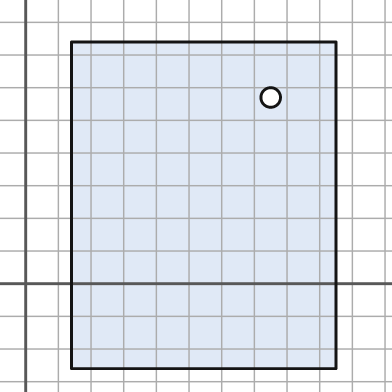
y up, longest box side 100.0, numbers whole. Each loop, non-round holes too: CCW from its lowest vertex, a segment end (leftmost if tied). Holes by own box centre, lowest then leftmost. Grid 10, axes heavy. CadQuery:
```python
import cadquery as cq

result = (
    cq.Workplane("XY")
    .moveTo(14.0, -26.0)
    .lineTo(95.0, -26.0)
    .lineTo(95.0, 74.0)
    .lineTo(14.0, 74.0)
    .close()
    .moveTo(75.0, 57.0)
    .circle(3.0)
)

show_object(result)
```